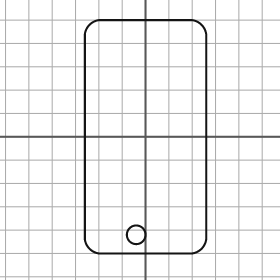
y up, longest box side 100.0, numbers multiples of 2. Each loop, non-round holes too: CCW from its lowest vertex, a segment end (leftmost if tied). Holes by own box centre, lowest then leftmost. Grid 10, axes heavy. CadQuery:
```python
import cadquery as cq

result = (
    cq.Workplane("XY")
    .moveTo(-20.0, -50.0)
    .lineTo(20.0, -50.0)
    .threePointArc((24.0, -48.0), (26.0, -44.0))
    .lineTo(26.0, 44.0)
    .threePointArc((24.0, 48.0), (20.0, 50.0))
    .lineTo(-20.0, 50.0)
    .threePointArc((-24.0, 48.0), (-26.0, 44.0))
    .lineTo(-26.0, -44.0)
    .threePointArc((-24.0, -48.0), (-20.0, -50.0))
    .close()
    .moveTo(-4.0, -42.0)
    .circle(4.0)
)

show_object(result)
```